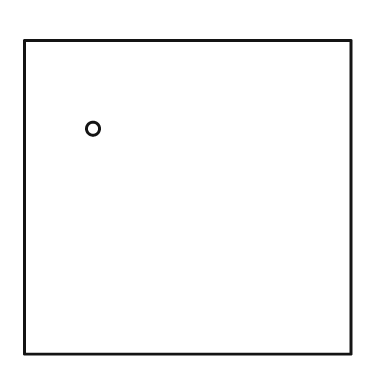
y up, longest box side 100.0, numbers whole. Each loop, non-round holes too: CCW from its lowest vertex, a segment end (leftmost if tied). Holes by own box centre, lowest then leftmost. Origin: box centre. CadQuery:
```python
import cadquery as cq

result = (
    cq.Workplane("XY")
    .moveTo(-50.0, -48.0)
    .lineTo(50.0, -48.0)
    .lineTo(50.0, 48.0)
    .lineTo(-50.0, 48.0)
    .close()
    .moveTo(-29.0, 21.0)
    .circle(2.0)
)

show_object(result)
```